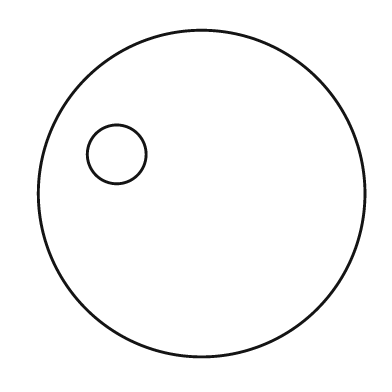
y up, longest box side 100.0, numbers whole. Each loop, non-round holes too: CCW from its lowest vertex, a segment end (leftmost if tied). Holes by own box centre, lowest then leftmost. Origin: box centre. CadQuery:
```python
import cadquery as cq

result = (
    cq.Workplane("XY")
    .moveTo(0.0, 0.0)
    .circle(50.0)
    .moveTo(-26.0, 12.0)
    .circle(9.0)
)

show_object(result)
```